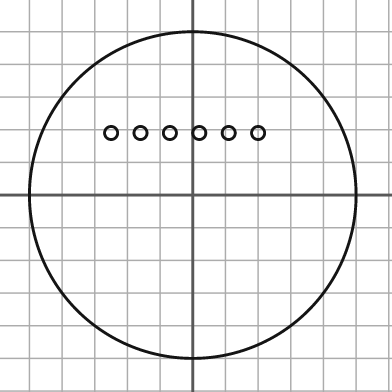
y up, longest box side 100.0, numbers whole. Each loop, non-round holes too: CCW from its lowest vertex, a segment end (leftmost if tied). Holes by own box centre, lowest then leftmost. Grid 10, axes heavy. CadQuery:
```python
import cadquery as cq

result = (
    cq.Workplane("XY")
    .moveTo(0.0, 0.0)
    .circle(50.0)
    .moveTo(-25.0, 19.0)
    .circle(2.0)
    .moveTo(-16.0, 19.0)
    .circle(2.0)
    .moveTo(-7.0, 19.0)
    .circle(2.0)
    .moveTo(2.0, 19.0)
    .circle(2.0)
    .moveTo(11.0, 19.0)
    .circle(2.0)
    .moveTo(20.0, 19.0)
    .circle(2.0)
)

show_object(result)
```